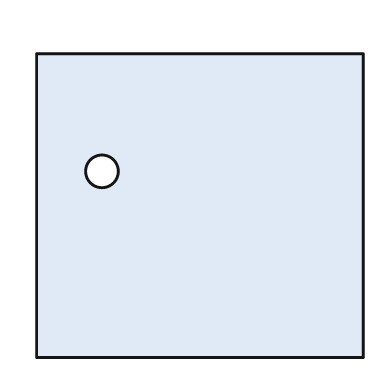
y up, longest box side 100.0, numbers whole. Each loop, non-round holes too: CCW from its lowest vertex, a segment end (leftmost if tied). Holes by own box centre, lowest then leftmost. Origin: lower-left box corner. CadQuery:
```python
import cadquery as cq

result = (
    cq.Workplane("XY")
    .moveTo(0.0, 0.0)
    .lineTo(100.0, 0.0)
    .lineTo(100.0, 93.0)
    .lineTo(0.0, 93.0)
    .close()
    .moveTo(20.0, 57.0)
    .circle(5.0)
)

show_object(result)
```